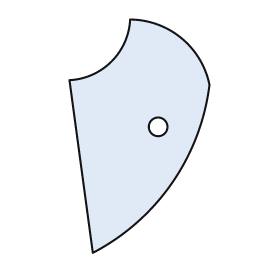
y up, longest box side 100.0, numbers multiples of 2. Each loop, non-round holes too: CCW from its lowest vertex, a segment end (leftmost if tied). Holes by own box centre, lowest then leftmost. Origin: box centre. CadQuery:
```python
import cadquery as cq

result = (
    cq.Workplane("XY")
    .moveTo(-20.0, -50.0)
    .threePointArc((14.0, -20.0), (30.0, 22.0))
    .threePointArc((18.0, 42.0), (-4.0, 50.0))
    .threePointArc((-12.0, 32.0), (-30.0, 24.0))
    .close()
    .moveTo(8.0, 4.0)
    .circle(4.0)
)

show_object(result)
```